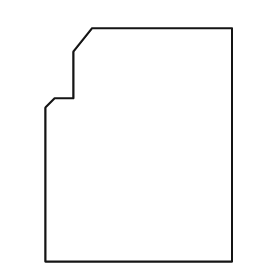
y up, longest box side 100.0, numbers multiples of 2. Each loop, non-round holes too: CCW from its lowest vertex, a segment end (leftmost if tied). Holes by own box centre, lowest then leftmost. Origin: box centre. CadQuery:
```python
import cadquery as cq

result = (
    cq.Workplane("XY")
    .moveTo(-40.0, -50.0)
    .lineTo(40.0, -50.0)
    .lineTo(40.0, 50.0)
    .lineTo(-20.0, 50.0)
    .lineTo(-28.0, 40.0)
    .lineTo(-28.0, 20.0)
    .lineTo(-36.0, 20.0)
    .lineTo(-40.0, 16.0)
    .close()
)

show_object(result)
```